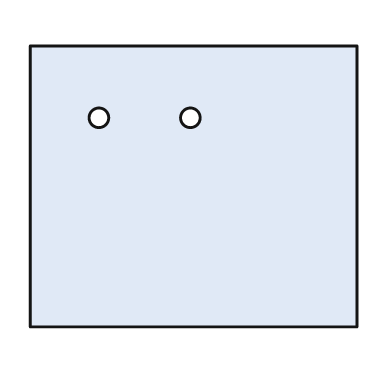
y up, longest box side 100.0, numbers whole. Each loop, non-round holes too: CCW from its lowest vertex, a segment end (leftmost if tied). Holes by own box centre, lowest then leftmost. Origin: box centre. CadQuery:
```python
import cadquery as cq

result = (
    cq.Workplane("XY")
    .moveTo(-50.0, -43.0)
    .lineTo(50.0, -43.0)
    .lineTo(50.0, 43.0)
    .lineTo(-50.0, 43.0)
    .close()
    .moveTo(-29.0, 21.0)
    .circle(3.0)
    .moveTo(-1.0, 21.0)
    .circle(3.0)
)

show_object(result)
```